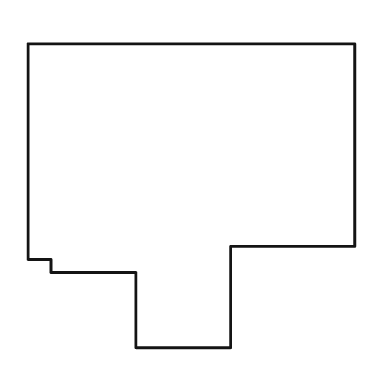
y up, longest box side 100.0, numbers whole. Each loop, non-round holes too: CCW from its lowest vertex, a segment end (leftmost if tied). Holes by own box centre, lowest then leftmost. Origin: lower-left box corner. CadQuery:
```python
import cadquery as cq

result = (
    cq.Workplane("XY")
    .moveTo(33.0, 0.0)
    .lineTo(62.0, 0.0)
    .lineTo(62.0, 31.0)
    .lineTo(100.0, 31.0)
    .lineTo(100.0, 93.0)
    .lineTo(0.0, 93.0)
    .lineTo(0.0, 27.0)
    .lineTo(7.0, 27.0)
    .lineTo(7.0, 23.0)
    .lineTo(33.0, 23.0)
    .close()
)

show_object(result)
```